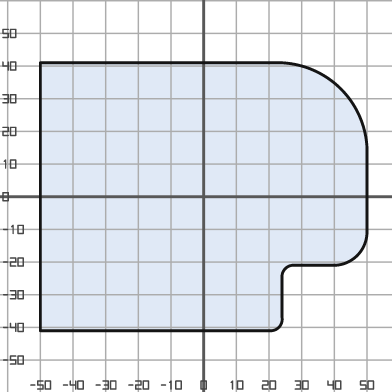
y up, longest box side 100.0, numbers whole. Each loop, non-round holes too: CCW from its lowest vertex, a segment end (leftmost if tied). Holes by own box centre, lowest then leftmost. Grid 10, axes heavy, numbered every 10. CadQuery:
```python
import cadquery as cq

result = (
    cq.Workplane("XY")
    .moveTo(-50.0, -41.0)
    .lineTo(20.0, -41.0)
    .threePointArc((23.0, -40.0), (24.0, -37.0))
    .lineTo(24.0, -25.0)
    .threePointArc((25.0, -22.0), (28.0, -21.0))
    .lineTo(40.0, -21.0)
    .threePointArc((47.0, -18.0), (50.0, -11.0))
    .lineTo(50.0, 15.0)
    .threePointArc((42.0, 33.0), (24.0, 41.0))
    .lineTo(-50.0, 41.0)
    .close()
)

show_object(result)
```